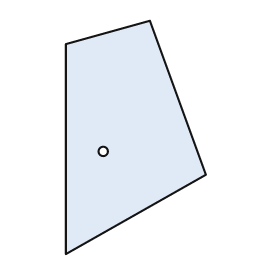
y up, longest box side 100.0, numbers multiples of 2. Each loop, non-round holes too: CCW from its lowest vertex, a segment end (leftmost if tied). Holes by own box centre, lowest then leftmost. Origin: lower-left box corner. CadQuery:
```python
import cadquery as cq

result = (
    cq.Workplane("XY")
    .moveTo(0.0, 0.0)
    .lineTo(60.0, 34.0)
    .lineTo(36.0, 100.0)
    .lineTo(0.0, 90.0)
    .close()
    .moveTo(16.0, 44.0)
    .circle(2.0)
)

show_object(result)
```